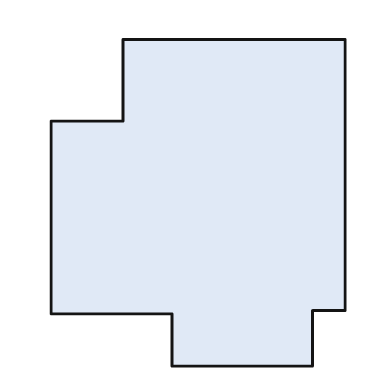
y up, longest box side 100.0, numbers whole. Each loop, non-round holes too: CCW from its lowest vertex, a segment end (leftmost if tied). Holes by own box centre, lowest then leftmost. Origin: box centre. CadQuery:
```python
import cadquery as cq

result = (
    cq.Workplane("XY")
    .moveTo(-8.0, -50.0)
    .lineTo(35.0, -50.0)
    .lineTo(35.0, -33.0)
    .lineTo(45.0, -33.0)
    .lineTo(45.0, 50.0)
    .lineTo(-23.0, 50.0)
    .lineTo(-23.0, 25.0)
    .lineTo(-45.0, 25.0)
    .lineTo(-45.0, -34.0)
    .lineTo(-8.0, -34.0)
    .close()
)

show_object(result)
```